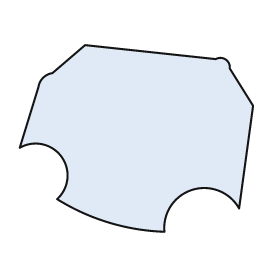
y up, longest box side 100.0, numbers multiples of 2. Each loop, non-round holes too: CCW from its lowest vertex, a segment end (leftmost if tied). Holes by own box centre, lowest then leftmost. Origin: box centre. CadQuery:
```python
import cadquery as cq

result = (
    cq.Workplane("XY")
    .moveTo(12.0, -40.0)
    .threePointArc((24.0, -22.0), (44.0, -30.0))
    .lineTo(50.0, 14.0)
    .lineTo(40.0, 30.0)
    .threePointArc((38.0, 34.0), (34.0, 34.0))
    .lineTo(-22.0, 40.0)
    .lineTo(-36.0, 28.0)
    .threePointArc((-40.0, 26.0), (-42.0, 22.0))
    .lineTo(-50.0, -4.0)
    .threePointArc((-32.0, -8.0), (-34.0, -26.0))
    .threePointArc((-12.0, -36.0), (12.0, -40.0))
    .close()
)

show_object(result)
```